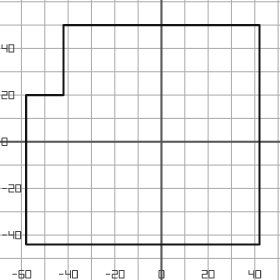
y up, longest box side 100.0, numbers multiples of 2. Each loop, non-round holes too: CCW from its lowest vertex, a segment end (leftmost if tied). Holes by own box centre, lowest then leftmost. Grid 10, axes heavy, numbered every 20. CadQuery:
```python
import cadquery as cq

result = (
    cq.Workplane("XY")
    .moveTo(-58.0, -44.0)
    .lineTo(42.0, -44.0)
    .lineTo(42.0, 50.0)
    .lineTo(-42.0, 50.0)
    .lineTo(-42.0, 20.0)
    .lineTo(-58.0, 20.0)
    .close()
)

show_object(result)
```